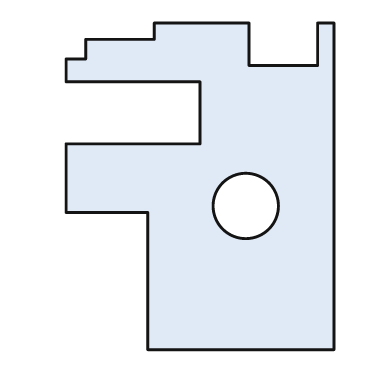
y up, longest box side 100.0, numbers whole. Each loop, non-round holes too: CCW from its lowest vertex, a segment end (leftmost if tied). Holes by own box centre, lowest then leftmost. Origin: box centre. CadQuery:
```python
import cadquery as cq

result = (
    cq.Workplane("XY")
    .moveTo(-16.0, -50.0)
    .lineTo(41.0, -50.0)
    .lineTo(41.0, 50.0)
    .lineTo(36.0, 50.0)
    .lineTo(36.0, 37.0)
    .lineTo(15.0, 37.0)
    .lineTo(15.0, 50.0)
    .lineTo(-14.0, 50.0)
    .lineTo(-14.0, 45.0)
    .lineTo(-35.0, 45.0)
    .lineTo(-35.0, 39.0)
    .lineTo(-41.0, 39.0)
    .lineTo(-41.0, 32.0)
    .lineTo(0.0, 32.0)
    .lineTo(0.0, 13.0)
    .lineTo(-41.0, 13.0)
    .lineTo(-41.0, -8.0)
    .lineTo(-16.0, -8.0)
    .close()
    .moveTo(14.0, -6.0)
    .circle(10.0)
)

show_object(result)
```